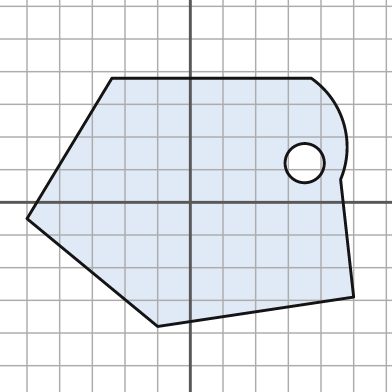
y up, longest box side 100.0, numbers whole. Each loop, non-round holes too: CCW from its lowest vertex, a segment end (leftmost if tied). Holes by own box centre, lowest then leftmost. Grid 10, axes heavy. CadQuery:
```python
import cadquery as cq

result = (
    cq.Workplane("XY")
    .moveTo(-10.0, -38.0)
    .lineTo(50.0, -29.0)
    .lineTo(46.0, 7.0)
    .threePointArc((47.0, 24.0), (37.0, 38.0))
    .lineTo(-24.0, 38.0)
    .lineTo(-50.0, -5.0)
    .close()
    .moveTo(35.0, 12.0)
    .circle(6.0)
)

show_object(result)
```